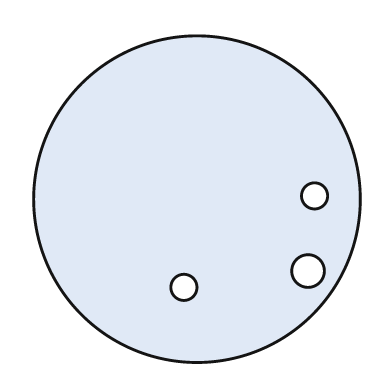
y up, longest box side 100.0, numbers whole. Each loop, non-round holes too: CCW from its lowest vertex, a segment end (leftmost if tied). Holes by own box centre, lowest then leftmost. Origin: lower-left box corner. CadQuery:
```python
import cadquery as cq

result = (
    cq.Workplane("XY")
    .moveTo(50.0, 50.0)
    .circle(50.0)
    .moveTo(46.0, 23.0)
    .circle(4.0)
    .moveTo(84.0, 28.0)
    .circle(5.0)
    .moveTo(86.0, 51.0)
    .circle(4.0)
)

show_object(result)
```